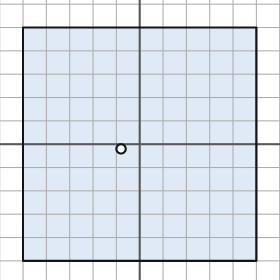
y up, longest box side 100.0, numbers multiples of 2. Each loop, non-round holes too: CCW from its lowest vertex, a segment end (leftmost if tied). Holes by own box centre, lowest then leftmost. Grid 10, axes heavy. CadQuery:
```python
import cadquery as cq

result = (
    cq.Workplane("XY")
    .moveTo(-50.0, -50.0)
    .lineTo(50.0, -50.0)
    .lineTo(50.0, 50.0)
    .lineTo(-50.0, 50.0)
    .close()
    .moveTo(-8.0, -2.0)
    .circle(2.0)
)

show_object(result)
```